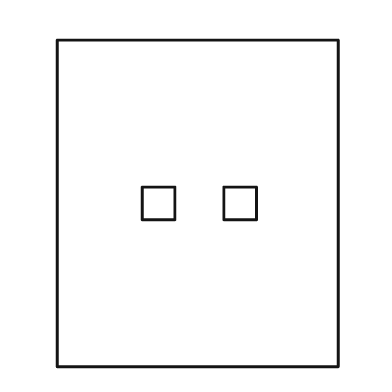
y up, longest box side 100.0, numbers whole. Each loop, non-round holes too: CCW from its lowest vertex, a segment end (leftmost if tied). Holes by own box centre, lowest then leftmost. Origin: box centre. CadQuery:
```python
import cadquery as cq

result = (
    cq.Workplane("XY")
    .moveTo(-43.0, -50.0)
    .lineTo(43.0, -50.0)
    .lineTo(43.0, 50.0)
    .lineTo(-43.0, 50.0)
    .close()
    .moveTo(-17.0, -5.0)
    .lineTo(-7.0, -5.0)
    .lineTo(-7.0, 5.0)
    .lineTo(-17.0, 5.0)
    .close()
    .moveTo(8.0, -5.0)
    .lineTo(18.0, -5.0)
    .lineTo(18.0, 5.0)
    .lineTo(8.0, 5.0)
    .close()
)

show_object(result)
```